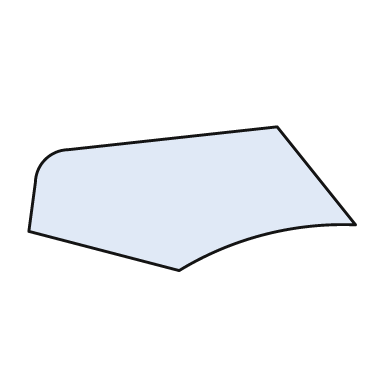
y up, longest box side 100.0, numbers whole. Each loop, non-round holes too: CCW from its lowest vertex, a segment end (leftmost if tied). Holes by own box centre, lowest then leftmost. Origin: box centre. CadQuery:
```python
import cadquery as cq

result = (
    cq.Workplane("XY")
    .moveTo(-4.0, -22.0)
    .threePointArc((22.0, -11.0), (50.0, -8.0))
    .lineTo(26.0, 22.0)
    .lineTo(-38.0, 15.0)
    .threePointArc((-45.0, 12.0), (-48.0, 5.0))
    .lineTo(-50.0, -10.0)
    .close()
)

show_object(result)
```